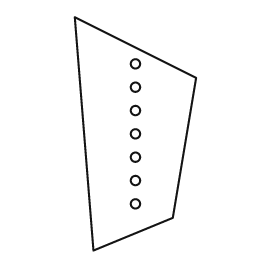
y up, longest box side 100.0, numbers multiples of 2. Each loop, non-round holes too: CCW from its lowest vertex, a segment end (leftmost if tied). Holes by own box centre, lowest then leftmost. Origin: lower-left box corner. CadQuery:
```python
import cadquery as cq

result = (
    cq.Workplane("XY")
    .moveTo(8.0, 0.0)
    .lineTo(42.0, 14.0)
    .lineTo(52.0, 74.0)
    .lineTo(0.0, 100.0)
    .close()
    .moveTo(26.0, 20.0)
    .circle(2.0)
    .moveTo(26.0, 30.0)
    .circle(2.0)
    .moveTo(26.0, 40.0)
    .circle(2.0)
    .moveTo(26.0, 50.0)
    .circle(2.0)
    .moveTo(26.0, 60.0)
    .circle(2.0)
    .moveTo(26.0, 70.0)
    .circle(2.0)
    .moveTo(26.0, 80.0)
    .circle(2.0)
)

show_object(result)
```